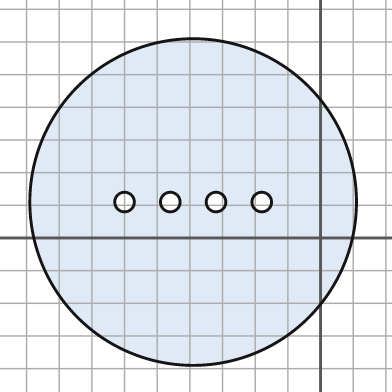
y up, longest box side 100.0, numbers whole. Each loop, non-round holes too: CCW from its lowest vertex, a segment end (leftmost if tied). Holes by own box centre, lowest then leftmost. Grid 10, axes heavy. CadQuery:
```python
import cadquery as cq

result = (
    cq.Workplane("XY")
    .moveTo(-39.0, 11.0)
    .circle(50.0)
    .moveTo(-60.0, 11.0)
    .circle(3.0)
    .moveTo(-46.0, 11.0)
    .circle(3.0)
    .moveTo(-32.0, 11.0)
    .circle(3.0)
    .moveTo(-18.0, 11.0)
    .circle(3.0)
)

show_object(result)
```